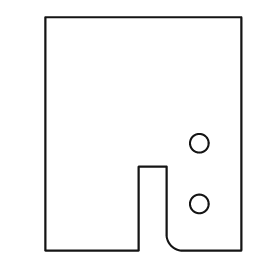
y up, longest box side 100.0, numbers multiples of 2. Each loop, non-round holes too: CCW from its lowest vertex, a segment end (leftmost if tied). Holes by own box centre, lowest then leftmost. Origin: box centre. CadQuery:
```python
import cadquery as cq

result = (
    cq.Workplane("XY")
    .moveTo(-42.0, -50.0)
    .lineTo(-2.0, -50.0)
    .lineTo(-2.0, -14.0)
    .lineTo(10.0, -14.0)
    .lineTo(10.0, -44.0)
    .threePointArc((12.0, -48.0), (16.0, -50.0))
    .lineTo(42.0, -50.0)
    .lineTo(42.0, 50.0)
    .lineTo(-42.0, 50.0)
    .close()
    .moveTo(24.0, -30.0)
    .circle(4.0)
    .moveTo(24.0, -4.0)
    .circle(4.0)
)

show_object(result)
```